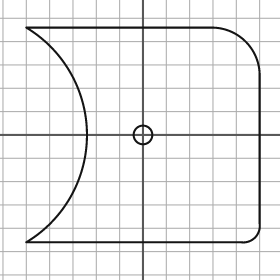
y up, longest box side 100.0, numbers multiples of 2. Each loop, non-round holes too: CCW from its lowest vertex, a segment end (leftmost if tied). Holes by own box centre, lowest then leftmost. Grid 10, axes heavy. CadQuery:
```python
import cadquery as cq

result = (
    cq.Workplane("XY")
    .moveTo(-50.0, -46.0)
    .lineTo(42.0, -46.0)
    .threePointArc((48.0, -44.0), (50.0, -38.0))
    .lineTo(50.0, 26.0)
    .threePointArc((44.0, 40.0), (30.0, 46.0))
    .lineTo(-50.0, 46.0)
    .threePointArc((-24.0, 0.0), (-50.0, -46.0))
    .close()
    .moveTo(0.0, 0.0)
    .circle(4.0)
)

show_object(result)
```